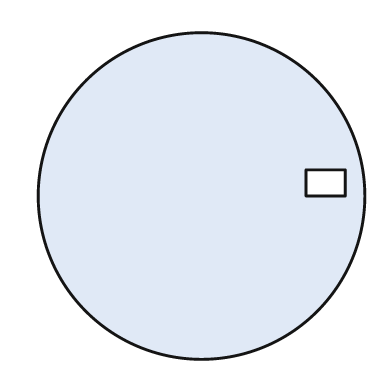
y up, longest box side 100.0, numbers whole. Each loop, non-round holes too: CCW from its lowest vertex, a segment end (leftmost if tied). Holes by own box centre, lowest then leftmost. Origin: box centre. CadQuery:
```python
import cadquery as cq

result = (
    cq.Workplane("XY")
    .moveTo(0.0, 0.0)
    .circle(50.0)
    .moveTo(32.0, 0.0)
    .lineTo(44.0, 0.0)
    .lineTo(44.0, 8.0)
    .lineTo(32.0, 8.0)
    .close()
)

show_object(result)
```